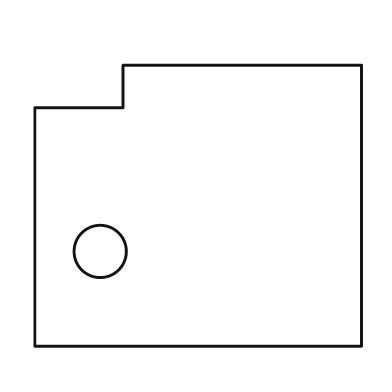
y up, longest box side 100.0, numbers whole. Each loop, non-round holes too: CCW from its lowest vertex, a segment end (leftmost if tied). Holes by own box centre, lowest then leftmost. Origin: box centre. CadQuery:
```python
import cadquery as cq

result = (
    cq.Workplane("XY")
    .moveTo(-50.0, -43.0)
    .lineTo(50.0, -43.0)
    .lineTo(50.0, 43.0)
    .lineTo(-23.0, 43.0)
    .lineTo(-23.0, 30.0)
    .lineTo(-50.0, 30.0)
    .close()
    .moveTo(-30.0, -14.0)
    .circle(8.0)
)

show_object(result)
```